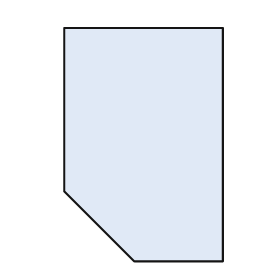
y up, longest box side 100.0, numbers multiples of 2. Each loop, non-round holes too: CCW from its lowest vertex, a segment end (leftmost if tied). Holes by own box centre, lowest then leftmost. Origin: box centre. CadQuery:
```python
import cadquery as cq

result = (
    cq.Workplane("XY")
    .moveTo(-4.0, -50.0)
    .lineTo(34.0, -50.0)
    .lineTo(34.0, 50.0)
    .lineTo(-34.0, 50.0)
    .lineTo(-34.0, -20.0)
    .close()
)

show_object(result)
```